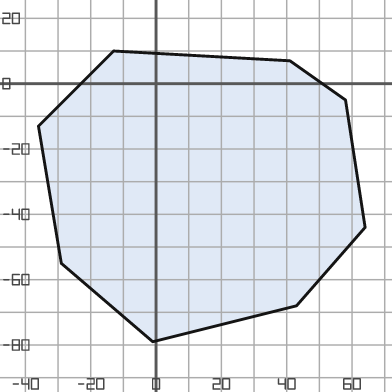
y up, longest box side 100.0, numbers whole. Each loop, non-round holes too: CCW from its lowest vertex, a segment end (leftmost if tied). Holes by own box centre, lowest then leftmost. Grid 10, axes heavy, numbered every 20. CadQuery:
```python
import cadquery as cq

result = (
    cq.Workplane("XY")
    .moveTo(-1.0, -79.0)
    .lineTo(43.0, -68.0)
    .lineTo(64.0, -44.0)
    .lineTo(58.0, -5.0)
    .lineTo(41.0, 7.0)
    .lineTo(-13.0, 10.0)
    .lineTo(-36.0, -13.0)
    .lineTo(-29.0, -55.0)
    .close()
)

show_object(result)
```